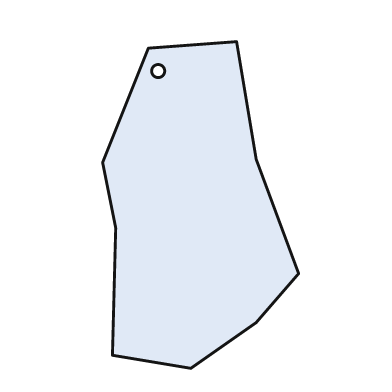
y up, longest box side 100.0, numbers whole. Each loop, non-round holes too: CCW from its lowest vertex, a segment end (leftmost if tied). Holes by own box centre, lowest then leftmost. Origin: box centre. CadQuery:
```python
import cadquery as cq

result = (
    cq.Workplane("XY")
    .moveTo(-3.0, -50.0)
    .lineTo(17.0, -36.0)
    .lineTo(30.0, -21.0)
    .lineTo(17.0, 14.0)
    .lineTo(11.0, 50.0)
    .lineTo(-16.0, 48.0)
    .lineTo(-30.0, 13.0)
    .lineTo(-26.0, -7.0)
    .lineTo(-27.0, -46.0)
    .close()
    .moveTo(-13.0, 41.0)
    .circle(2.0)
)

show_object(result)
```